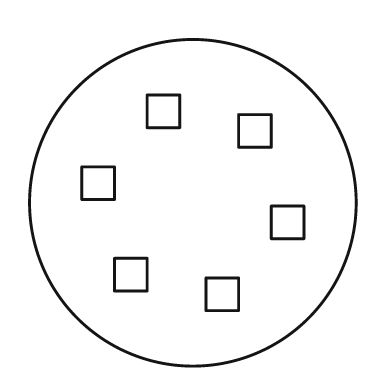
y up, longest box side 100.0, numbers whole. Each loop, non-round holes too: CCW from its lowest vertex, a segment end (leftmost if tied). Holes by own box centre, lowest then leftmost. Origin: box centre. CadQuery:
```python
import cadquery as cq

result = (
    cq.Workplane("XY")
    .moveTo(0.0, 0.0)
    .circle(50.0)
    .moveTo(4.0, -33.0)
    .lineTo(14.0, -33.0)
    .lineTo(14.0, -23.0)
    .lineTo(4.0, -23.0)
    .close()
    .moveTo(-24.0, -27.0)
    .lineTo(-14.0, -27.0)
    .lineTo(-14.0, -17.0)
    .lineTo(-24.0, -17.0)
    .close()
    .moveTo(24.0, -11.0)
    .lineTo(34.0, -11.0)
    .lineTo(34.0, -1.0)
    .lineTo(24.0, -1.0)
    .close()
    .moveTo(-34.0, 1.0)
    .lineTo(-24.0, 1.0)
    .lineTo(-24.0, 11.0)
    .lineTo(-34.0, 11.0)
    .close()
    .moveTo(14.0, 17.0)
    .lineTo(24.0, 17.0)
    .lineTo(24.0, 27.0)
    .lineTo(14.0, 27.0)
    .close()
    .moveTo(-14.0, 23.0)
    .lineTo(-4.0, 23.0)
    .lineTo(-4.0, 33.0)
    .lineTo(-14.0, 33.0)
    .close()
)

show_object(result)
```